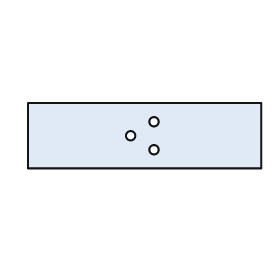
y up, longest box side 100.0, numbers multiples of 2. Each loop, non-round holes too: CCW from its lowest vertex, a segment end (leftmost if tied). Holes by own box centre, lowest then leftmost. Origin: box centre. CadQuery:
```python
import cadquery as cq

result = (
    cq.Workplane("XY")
    .moveTo(-50.0, -14.0)
    .lineTo(50.0, -14.0)
    .lineTo(50.0, 14.0)
    .lineTo(-50.0, 14.0)
    .close()
    .moveTo(4.0, -6.0)
    .circle(2.0)
    .moveTo(-6.0, 0.0)
    .circle(2.0)
    .moveTo(4.0, 6.0)
    .circle(2.0)
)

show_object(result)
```